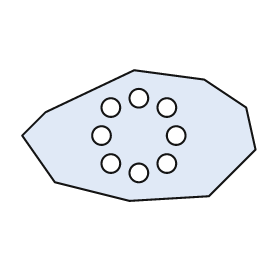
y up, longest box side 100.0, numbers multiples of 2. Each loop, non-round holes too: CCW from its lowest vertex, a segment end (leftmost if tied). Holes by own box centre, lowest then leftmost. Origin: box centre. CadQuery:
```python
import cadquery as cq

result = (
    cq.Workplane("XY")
    .moveTo(-4.0, -28.0)
    .lineTo(30.0, -26.0)
    .lineTo(50.0, -6.0)
    .lineTo(46.0, 12.0)
    .lineTo(28.0, 24.0)
    .lineTo(-2.0, 28.0)
    .lineTo(-40.0, 10.0)
    .lineTo(-50.0, 0.0)
    .lineTo(-36.0, -20.0)
    .close()
    .moveTo(0.0, -16.0)
    .circle(4.0)
    .moveTo(-12.0, -12.0)
    .circle(4.0)
    .moveTo(12.0, -12.0)
    .circle(4.0)
    .moveTo(-16.0, 0.0)
    .circle(4.0)
    .moveTo(16.0, 0.0)
    .circle(4.0)
    .moveTo(-12.0, 12.0)
    .circle(4.0)
    .moveTo(12.0, 12.0)
    .circle(4.0)
    .moveTo(0.0, 16.0)
    .circle(4.0)
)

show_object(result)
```